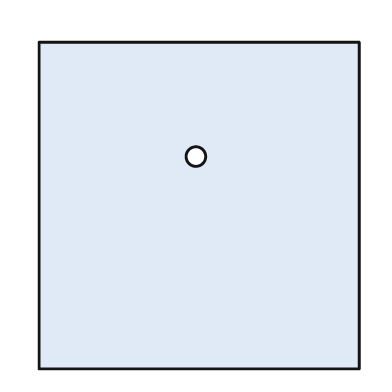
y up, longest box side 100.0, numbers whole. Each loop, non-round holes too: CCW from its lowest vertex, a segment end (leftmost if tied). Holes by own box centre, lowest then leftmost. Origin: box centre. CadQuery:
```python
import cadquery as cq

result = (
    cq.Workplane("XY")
    .moveTo(-49.0, -50.0)
    .lineTo(49.0, -50.0)
    .lineTo(49.0, 50.0)
    .lineTo(-49.0, 50.0)
    .close()
    .moveTo(-1.0, 15.0)
    .circle(3.0)
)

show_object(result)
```